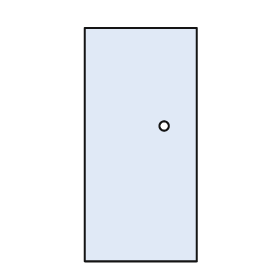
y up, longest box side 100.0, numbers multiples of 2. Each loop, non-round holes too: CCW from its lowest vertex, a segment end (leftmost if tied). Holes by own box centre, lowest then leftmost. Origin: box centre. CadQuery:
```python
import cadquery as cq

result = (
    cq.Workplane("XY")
    .moveTo(-24.0, -50.0)
    .lineTo(24.0, -50.0)
    .lineTo(24.0, 50.0)
    .lineTo(-24.0, 50.0)
    .close()
    .moveTo(10.0, 8.0)
    .circle(2.0)
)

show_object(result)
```